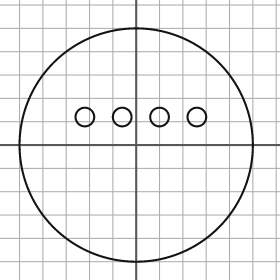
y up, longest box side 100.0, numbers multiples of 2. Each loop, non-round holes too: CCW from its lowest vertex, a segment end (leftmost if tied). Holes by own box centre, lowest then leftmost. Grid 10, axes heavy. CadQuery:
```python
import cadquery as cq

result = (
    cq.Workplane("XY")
    .moveTo(0.0, 0.0)
    .circle(50.0)
    .moveTo(-22.0, 12.0)
    .circle(4.0)
    .moveTo(-6.0, 12.0)
    .circle(4.0)
    .moveTo(10.0, 12.0)
    .circle(4.0)
    .moveTo(26.0, 12.0)
    .circle(4.0)
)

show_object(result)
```